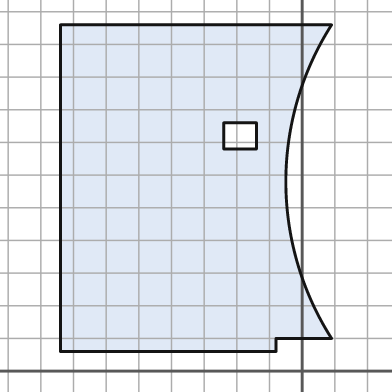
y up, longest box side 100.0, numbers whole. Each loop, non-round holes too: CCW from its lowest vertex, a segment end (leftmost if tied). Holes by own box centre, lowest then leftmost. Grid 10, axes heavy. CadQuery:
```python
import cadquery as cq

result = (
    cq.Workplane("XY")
    .moveTo(-74.0, 6.0)
    .lineTo(-8.0, 6.0)
    .lineTo(-8.0, 10.0)
    .lineTo(9.0, 10.0)
    .threePointArc((-5.0, 58.0), (9.0, 106.0))
    .lineTo(-74.0, 106.0)
    .close()
    .moveTo(-24.0, 68.0)
    .lineTo(-14.0, 68.0)
    .lineTo(-14.0, 76.0)
    .lineTo(-24.0, 76.0)
    .close()
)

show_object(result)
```